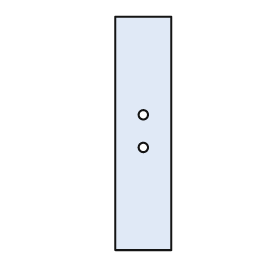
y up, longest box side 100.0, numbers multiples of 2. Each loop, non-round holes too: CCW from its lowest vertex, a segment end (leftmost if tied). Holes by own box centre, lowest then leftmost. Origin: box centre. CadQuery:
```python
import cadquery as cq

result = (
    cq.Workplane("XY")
    .moveTo(-12.0, -50.0)
    .lineTo(12.0, -50.0)
    .lineTo(12.0, 50.0)
    .lineTo(-12.0, 50.0)
    .close()
    .moveTo(0.0, -6.0)
    .circle(2.0)
    .moveTo(0.0, 8.0)
    .circle(2.0)
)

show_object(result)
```